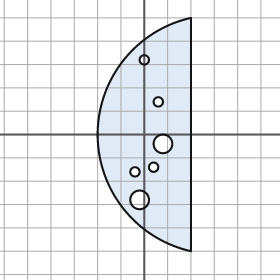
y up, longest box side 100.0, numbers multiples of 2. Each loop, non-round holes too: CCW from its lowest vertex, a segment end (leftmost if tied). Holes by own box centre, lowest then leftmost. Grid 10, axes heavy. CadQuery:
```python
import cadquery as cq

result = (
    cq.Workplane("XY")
    .moveTo(20.0, -50.0)
    .lineTo(20.0, 50.0)
    .threePointArc((-20.0, 0.0), (20.0, -50.0))
    .close()
    .moveTo(-2.0, -28.0)
    .circle(4.0)
    .moveTo(-4.0, -16.0)
    .circle(2.0)
    .moveTo(4.0, -14.0)
    .circle(2.0)
    .moveTo(8.0, -4.0)
    .circle(4.0)
    .moveTo(6.0, 14.0)
    .circle(2.0)
    .moveTo(0.0, 32.0)
    .circle(2.0)
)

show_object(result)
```